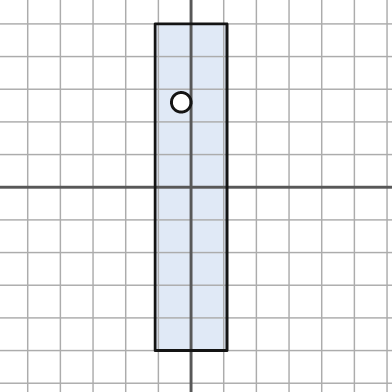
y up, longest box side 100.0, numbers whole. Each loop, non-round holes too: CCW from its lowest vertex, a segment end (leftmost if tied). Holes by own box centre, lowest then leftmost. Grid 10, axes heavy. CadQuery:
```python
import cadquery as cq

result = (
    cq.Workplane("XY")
    .moveTo(-11.0, -50.0)
    .lineTo(11.0, -50.0)
    .lineTo(11.0, 50.0)
    .lineTo(-11.0, 50.0)
    .close()
    .moveTo(-3.0, 26.0)
    .circle(3.0)
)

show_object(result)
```